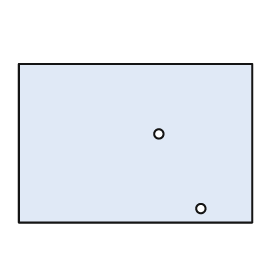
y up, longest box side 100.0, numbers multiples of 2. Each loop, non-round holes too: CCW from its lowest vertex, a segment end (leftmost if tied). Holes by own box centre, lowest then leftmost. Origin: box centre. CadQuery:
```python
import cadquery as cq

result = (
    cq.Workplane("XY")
    .moveTo(-50.0, -34.0)
    .lineTo(50.0, -34.0)
    .lineTo(50.0, 34.0)
    .lineTo(-50.0, 34.0)
    .close()
    .moveTo(28.0, -28.0)
    .circle(2.0)
    .moveTo(10.0, 4.0)
    .circle(2.0)
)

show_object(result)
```